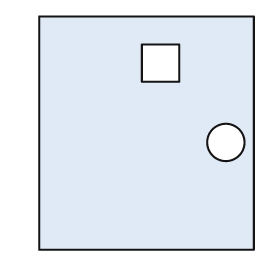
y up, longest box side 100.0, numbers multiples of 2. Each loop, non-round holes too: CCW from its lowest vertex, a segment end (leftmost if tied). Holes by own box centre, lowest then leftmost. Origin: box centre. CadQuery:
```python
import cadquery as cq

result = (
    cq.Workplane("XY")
    .moveTo(-46.0, -50.0)
    .lineTo(46.0, -50.0)
    .lineTo(46.0, 50.0)
    .lineTo(-46.0, 50.0)
    .close()
    .moveTo(34.0, -4.0)
    .circle(8.0)
    .moveTo(-2.0, 22.0)
    .lineTo(14.0, 22.0)
    .lineTo(14.0, 38.0)
    .lineTo(-2.0, 38.0)
    .close()
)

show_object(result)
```